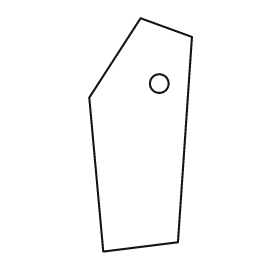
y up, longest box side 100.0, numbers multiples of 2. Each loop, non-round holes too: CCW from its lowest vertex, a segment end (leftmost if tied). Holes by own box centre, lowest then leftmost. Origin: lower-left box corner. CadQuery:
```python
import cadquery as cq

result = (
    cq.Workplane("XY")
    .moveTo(6.0, 0.0)
    .lineTo(38.0, 4.0)
    .lineTo(44.0, 92.0)
    .lineTo(22.0, 100.0)
    .lineTo(0.0, 66.0)
    .close()
    .moveTo(30.0, 72.0)
    .circle(4.0)
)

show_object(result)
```